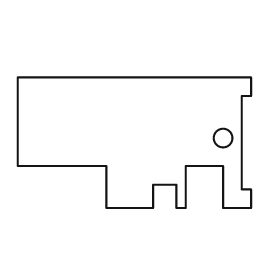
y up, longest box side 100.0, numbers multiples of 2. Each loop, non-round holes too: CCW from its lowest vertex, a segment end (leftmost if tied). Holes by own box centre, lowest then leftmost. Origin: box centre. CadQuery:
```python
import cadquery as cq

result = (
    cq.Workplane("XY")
    .moveTo(-12.0, -28.0)
    .lineTo(8.0, -28.0)
    .lineTo(8.0, -18.0)
    .lineTo(18.0, -18.0)
    .lineTo(18.0, -28.0)
    .lineTo(22.0, -28.0)
    .lineTo(22.0, -10.0)
    .lineTo(38.0, -10.0)
    .lineTo(38.0, -28.0)
    .lineTo(50.0, -28.0)
    .lineTo(50.0, -20.0)
    .lineTo(46.0, -20.0)
    .lineTo(46.0, 20.0)
    .lineTo(50.0, 20.0)
    .lineTo(50.0, 28.0)
    .lineTo(-50.0, 28.0)
    .lineTo(-50.0, -10.0)
    .lineTo(-12.0, -10.0)
    .close()
    .moveTo(38.0, 2.0)
    .circle(4.0)
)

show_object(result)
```